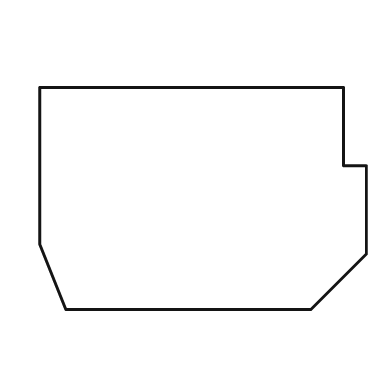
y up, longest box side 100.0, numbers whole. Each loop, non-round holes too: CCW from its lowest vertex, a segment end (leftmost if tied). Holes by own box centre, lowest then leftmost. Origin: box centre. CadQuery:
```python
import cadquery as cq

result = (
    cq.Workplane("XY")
    .moveTo(-42.0, -34.0)
    .lineTo(33.0, -34.0)
    .lineTo(50.0, -17.0)
    .lineTo(50.0, 10.0)
    .lineTo(43.0, 10.0)
    .lineTo(43.0, 34.0)
    .lineTo(-50.0, 34.0)
    .lineTo(-50.0, -14.0)
    .close()
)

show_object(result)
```